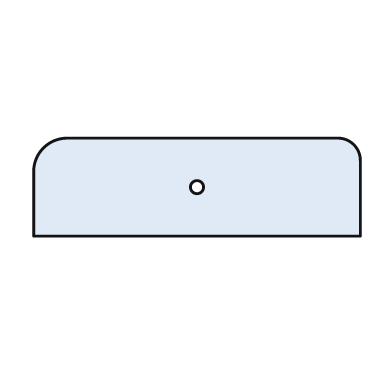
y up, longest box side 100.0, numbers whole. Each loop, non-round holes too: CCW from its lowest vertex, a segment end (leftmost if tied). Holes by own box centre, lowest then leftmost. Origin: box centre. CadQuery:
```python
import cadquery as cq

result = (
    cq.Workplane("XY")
    .moveTo(-50.0, -15.0)
    .lineTo(50.0, -15.0)
    .lineTo(50.0, 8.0)
    .threePointArc((48.0, 13.0), (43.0, 15.0))
    .lineTo(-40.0, 15.0)
    .threePointArc((-47.0, 12.0), (-50.0, 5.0))
    .close()
    .moveTo(0.0, 0.0)
    .circle(2.0)
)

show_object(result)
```